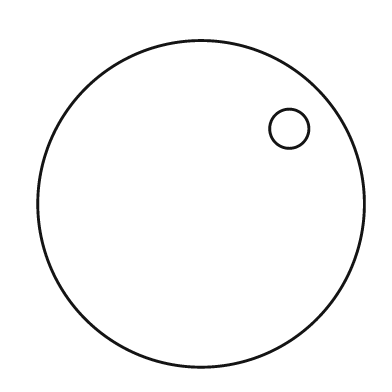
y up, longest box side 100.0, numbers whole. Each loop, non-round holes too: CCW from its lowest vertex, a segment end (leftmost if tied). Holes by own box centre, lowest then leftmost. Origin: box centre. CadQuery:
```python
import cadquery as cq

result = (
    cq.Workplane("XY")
    .moveTo(0.0, 0.0)
    .circle(50.0)
    .moveTo(27.0, 23.0)
    .circle(6.0)
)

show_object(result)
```